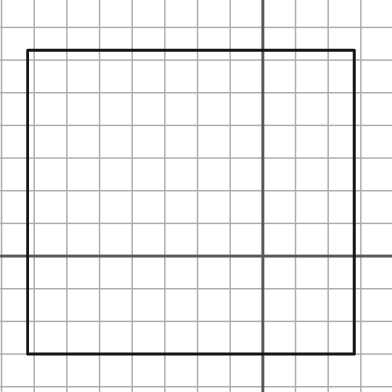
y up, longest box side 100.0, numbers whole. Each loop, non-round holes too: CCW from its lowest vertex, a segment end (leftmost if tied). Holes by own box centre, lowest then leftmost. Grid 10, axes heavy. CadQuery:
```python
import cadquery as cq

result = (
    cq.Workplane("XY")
    .moveTo(-72.0, -30.0)
    .lineTo(28.0, -30.0)
    .lineTo(28.0, 63.0)
    .lineTo(-72.0, 63.0)
    .close()
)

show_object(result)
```